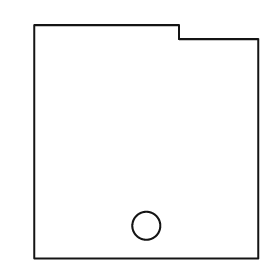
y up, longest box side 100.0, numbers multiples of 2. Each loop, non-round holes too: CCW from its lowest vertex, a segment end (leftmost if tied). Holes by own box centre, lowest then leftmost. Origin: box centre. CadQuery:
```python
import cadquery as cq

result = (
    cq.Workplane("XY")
    .moveTo(-48.0, -50.0)
    .lineTo(48.0, -50.0)
    .lineTo(48.0, 44.0)
    .lineTo(14.0, 44.0)
    .lineTo(14.0, 50.0)
    .lineTo(-48.0, 50.0)
    .close()
    .moveTo(0.0, -36.0)
    .circle(6.0)
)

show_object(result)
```